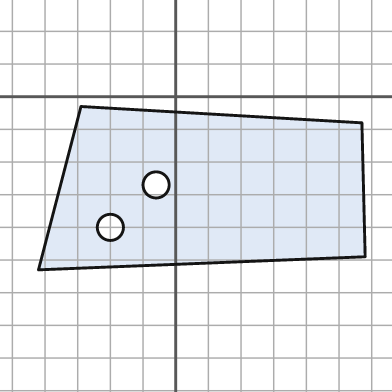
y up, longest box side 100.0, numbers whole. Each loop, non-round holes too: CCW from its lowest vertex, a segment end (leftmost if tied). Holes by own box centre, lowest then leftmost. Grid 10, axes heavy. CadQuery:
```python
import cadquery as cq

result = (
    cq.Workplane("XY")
    .moveTo(-42.0, -53.0)
    .lineTo(58.0, -49.0)
    .lineTo(57.0, -8.0)
    .lineTo(-29.0, -3.0)
    .close()
    .moveTo(-20.0, -40.0)
    .circle(4.0)
    .moveTo(-6.0, -27.0)
    .circle(4.0)
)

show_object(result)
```